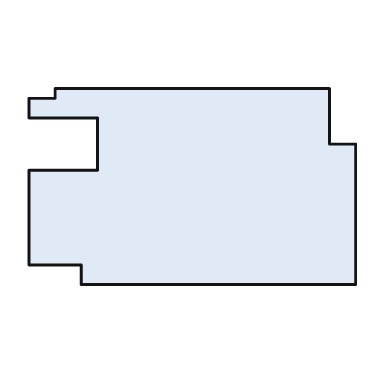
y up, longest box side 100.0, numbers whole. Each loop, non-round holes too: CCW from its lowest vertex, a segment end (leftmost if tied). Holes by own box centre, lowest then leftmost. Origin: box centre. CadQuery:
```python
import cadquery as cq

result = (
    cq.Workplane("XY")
    .moveTo(-34.0, -30.0)
    .lineTo(50.0, -30.0)
    .lineTo(50.0, 13.0)
    .lineTo(42.0, 13.0)
    .lineTo(42.0, 30.0)
    .lineTo(-42.0, 30.0)
    .lineTo(-42.0, 27.0)
    .lineTo(-50.0, 27.0)
    .lineTo(-50.0, 21.0)
    .lineTo(-29.0, 21.0)
    .lineTo(-29.0, 5.0)
    .lineTo(-50.0, 5.0)
    .lineTo(-50.0, -24.0)
    .lineTo(-34.0, -24.0)
    .close()
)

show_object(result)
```